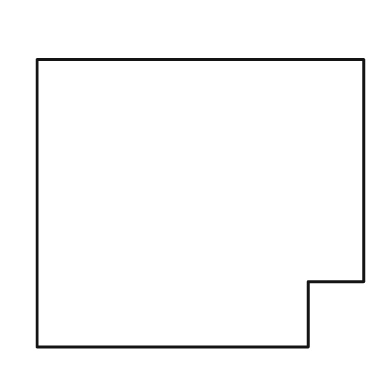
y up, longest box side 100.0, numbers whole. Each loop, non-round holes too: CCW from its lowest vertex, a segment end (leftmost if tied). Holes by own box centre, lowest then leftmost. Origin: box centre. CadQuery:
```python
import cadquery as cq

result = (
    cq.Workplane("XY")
    .moveTo(-50.0, -44.0)
    .lineTo(33.0, -44.0)
    .lineTo(33.0, -24.0)
    .lineTo(50.0, -24.0)
    .lineTo(50.0, 44.0)
    .lineTo(-50.0, 44.0)
    .close()
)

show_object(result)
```